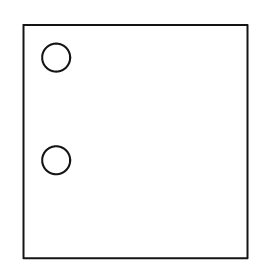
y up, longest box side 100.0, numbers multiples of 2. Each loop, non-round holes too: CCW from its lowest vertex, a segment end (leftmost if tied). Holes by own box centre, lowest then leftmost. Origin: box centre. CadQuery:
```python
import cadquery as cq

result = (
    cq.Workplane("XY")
    .moveTo(-48.0, -50.0)
    .lineTo(48.0, -50.0)
    .lineTo(48.0, 50.0)
    .lineTo(-48.0, 50.0)
    .close()
    .moveTo(-34.0, -8.0)
    .circle(6.0)
    .moveTo(-34.0, 36.0)
    .circle(6.0)
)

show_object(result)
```